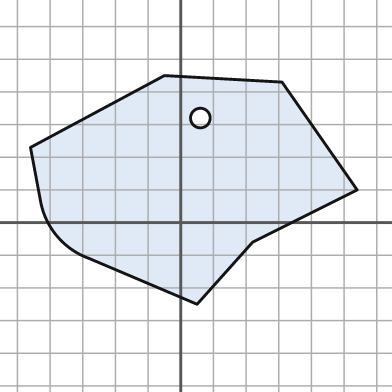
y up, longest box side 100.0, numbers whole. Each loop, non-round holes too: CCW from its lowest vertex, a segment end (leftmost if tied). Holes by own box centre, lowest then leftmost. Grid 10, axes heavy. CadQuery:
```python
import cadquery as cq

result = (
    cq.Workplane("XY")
    .moveTo(5.0, -25.0)
    .lineTo(22.0, -6.0)
    .lineTo(54.0, 10.0)
    .lineTo(31.0, 43.0)
    .lineTo(-5.0, 45.0)
    .lineTo(-46.0, 23.0)
    .lineTo(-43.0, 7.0)
    .threePointArc((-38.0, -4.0), (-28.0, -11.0))
    .close()
    .moveTo(6.0, 32.0)
    .circle(3.0)
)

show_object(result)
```